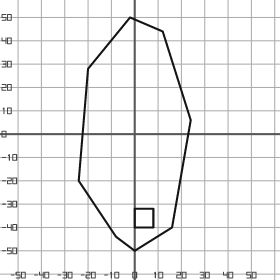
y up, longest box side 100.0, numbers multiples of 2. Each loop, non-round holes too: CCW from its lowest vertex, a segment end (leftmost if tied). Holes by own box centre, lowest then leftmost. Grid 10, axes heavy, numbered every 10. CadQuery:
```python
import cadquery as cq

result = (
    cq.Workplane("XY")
    .moveTo(0.0, -50.0)
    .lineTo(16.0, -40.0)
    .lineTo(24.0, 6.0)
    .lineTo(12.0, 44.0)
    .lineTo(-2.0, 50.0)
    .lineTo(-20.0, 28.0)
    .lineTo(-24.0, -20.0)
    .lineTo(-8.0, -44.0)
    .close()
    .moveTo(0.0, -40.0)
    .lineTo(8.0, -40.0)
    .lineTo(8.0, -32.0)
    .lineTo(0.0, -32.0)
    .close()
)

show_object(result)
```